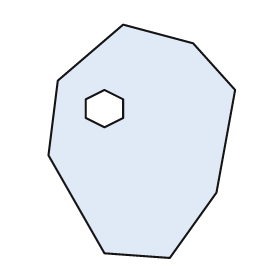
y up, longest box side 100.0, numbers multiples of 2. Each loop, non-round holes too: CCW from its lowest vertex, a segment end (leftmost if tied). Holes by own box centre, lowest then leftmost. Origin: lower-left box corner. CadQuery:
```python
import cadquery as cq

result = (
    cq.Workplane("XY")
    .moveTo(52.0, 0.0)
    .lineTo(72.0, 28.0)
    .lineTo(80.0, 72.0)
    .lineTo(62.0, 92.0)
    .lineTo(32.0, 100.0)
    .lineTo(4.0, 76.0)
    .lineTo(0.0, 44.0)
    .lineTo(24.0, 2.0)
    .close()
    .moveTo(24.0, 56.0)
    .lineTo(32.0, 60.0)
    .lineTo(32.0, 68.0)
    .lineTo(24.0, 72.0)
    .lineTo(16.0, 68.0)
    .lineTo(16.0, 60.0)
    .close()
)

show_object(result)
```